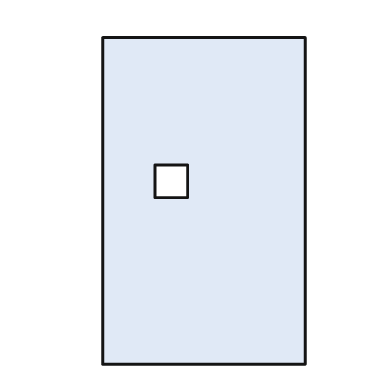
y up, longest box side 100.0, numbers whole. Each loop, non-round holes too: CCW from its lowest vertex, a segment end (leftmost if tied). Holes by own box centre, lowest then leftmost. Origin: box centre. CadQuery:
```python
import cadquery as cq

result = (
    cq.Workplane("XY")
    .moveTo(-31.0, -50.0)
    .lineTo(31.0, -50.0)
    .lineTo(31.0, 50.0)
    .lineTo(-31.0, 50.0)
    .close()
    .moveTo(-15.0, 1.0)
    .lineTo(-5.0, 1.0)
    .lineTo(-5.0, 11.0)
    .lineTo(-15.0, 11.0)
    .close()
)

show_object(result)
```